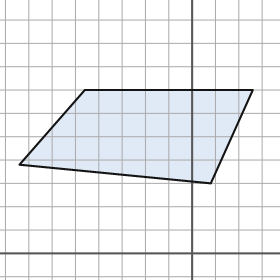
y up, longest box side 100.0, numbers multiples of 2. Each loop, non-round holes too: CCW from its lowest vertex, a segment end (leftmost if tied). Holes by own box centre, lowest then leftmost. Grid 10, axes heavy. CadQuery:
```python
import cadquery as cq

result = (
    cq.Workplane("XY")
    .moveTo(8.0, 30.0)
    .lineTo(26.0, 70.0)
    .lineTo(-46.0, 70.0)
    .lineTo(-74.0, 38.0)
    .close()
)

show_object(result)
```